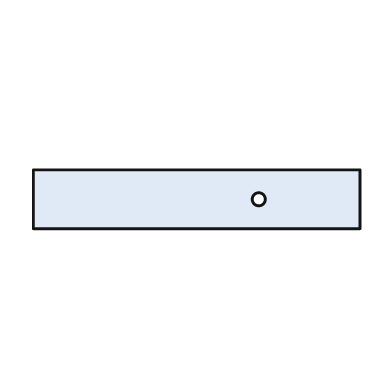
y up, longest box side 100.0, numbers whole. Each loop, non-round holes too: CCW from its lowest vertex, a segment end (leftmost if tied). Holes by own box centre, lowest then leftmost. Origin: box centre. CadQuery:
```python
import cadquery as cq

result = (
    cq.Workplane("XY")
    .moveTo(-50.0, -9.0)
    .lineTo(50.0, -9.0)
    .lineTo(50.0, 9.0)
    .lineTo(-50.0, 9.0)
    .close()
    .moveTo(19.0, 0.0)
    .circle(2.0)
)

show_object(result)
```